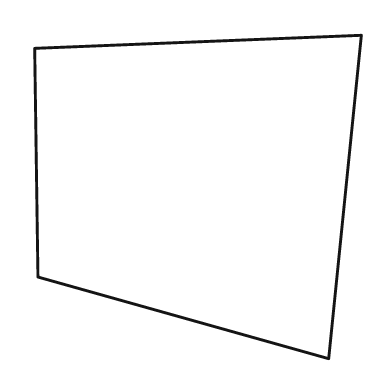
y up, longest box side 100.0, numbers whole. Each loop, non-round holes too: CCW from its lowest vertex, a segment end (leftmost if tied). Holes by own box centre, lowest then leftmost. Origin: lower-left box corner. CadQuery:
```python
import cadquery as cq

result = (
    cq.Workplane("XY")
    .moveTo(90.0, 0.0)
    .lineTo(100.0, 99.0)
    .lineTo(0.0, 95.0)
    .lineTo(1.0, 25.0)
    .close()
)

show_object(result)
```